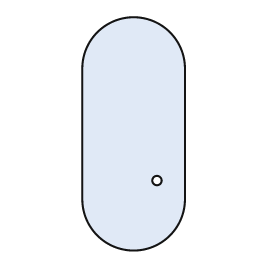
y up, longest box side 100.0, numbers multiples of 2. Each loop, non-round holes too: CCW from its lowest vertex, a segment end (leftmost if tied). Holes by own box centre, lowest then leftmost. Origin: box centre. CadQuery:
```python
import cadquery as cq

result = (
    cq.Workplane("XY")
    .moveTo(-22.0, -28.0)
    .threePointArc((0.0, -50.0), (22.0, -28.0))
    .lineTo(22.0, 28.0)
    .threePointArc((0.0, 50.0), (-22.0, 28.0))
    .close()
    .moveTo(10.0, -20.0)
    .circle(2.0)
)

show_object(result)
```